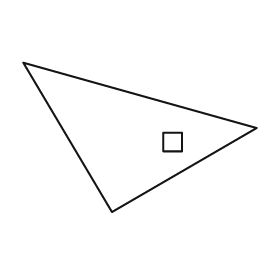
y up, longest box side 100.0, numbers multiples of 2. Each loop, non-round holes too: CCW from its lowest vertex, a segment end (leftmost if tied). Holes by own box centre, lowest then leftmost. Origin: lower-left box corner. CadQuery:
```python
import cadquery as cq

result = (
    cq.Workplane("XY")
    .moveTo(38.0, 0.0)
    .lineTo(100.0, 36.0)
    .lineTo(0.0, 64.0)
    .close()
    .moveTo(60.0, 26.0)
    .lineTo(68.0, 26.0)
    .lineTo(68.0, 34.0)
    .lineTo(60.0, 34.0)
    .close()
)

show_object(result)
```